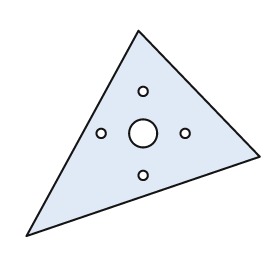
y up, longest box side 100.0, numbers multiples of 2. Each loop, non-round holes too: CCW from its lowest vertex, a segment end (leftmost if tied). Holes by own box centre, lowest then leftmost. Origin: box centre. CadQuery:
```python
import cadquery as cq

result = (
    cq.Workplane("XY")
    .moveTo(-50.0, -44.0)
    .lineTo(50.0, -10.0)
    .lineTo(-2.0, 44.0)
    .close()
    .moveTo(0.0, -18.0)
    .circle(2.0)
    .moveTo(-18.0, 0.0)
    .circle(2.0)
    .moveTo(0.0, 0.0)
    .circle(6.0)
    .moveTo(18.0, 0.0)
    .circle(2.0)
    .moveTo(0.0, 18.0)
    .circle(2.0)
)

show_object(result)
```